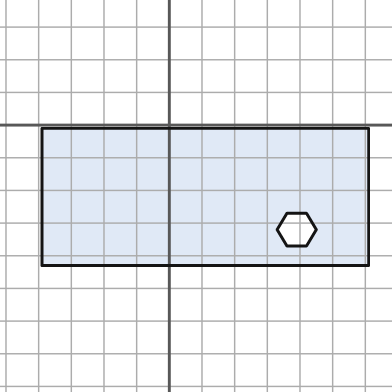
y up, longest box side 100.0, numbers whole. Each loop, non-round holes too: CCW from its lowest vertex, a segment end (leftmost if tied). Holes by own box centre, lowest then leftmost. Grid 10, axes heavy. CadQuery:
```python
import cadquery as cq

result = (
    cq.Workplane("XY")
    .moveTo(-39.0, -43.0)
    .lineTo(61.0, -43.0)
    .lineTo(61.0, -1.0)
    .lineTo(-39.0, -1.0)
    .close()
    .moveTo(36.0, -37.0)
    .lineTo(42.0, -37.0)
    .lineTo(45.0, -32.0)
    .lineTo(42.0, -27.0)
    .lineTo(36.0, -27.0)
    .lineTo(33.0, -32.0)
    .close()
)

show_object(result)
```